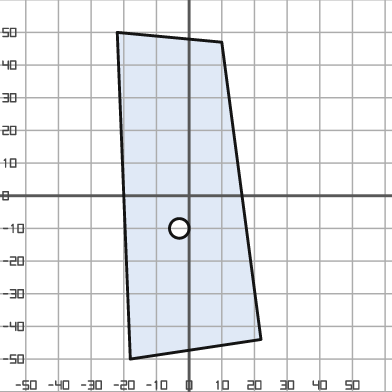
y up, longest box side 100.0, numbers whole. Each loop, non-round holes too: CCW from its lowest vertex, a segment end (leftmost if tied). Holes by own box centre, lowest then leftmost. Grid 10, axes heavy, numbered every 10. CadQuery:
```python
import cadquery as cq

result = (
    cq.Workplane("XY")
    .moveTo(-18.0, -50.0)
    .lineTo(22.0, -44.0)
    .lineTo(10.0, 47.0)
    .lineTo(-22.0, 50.0)
    .close()
    .moveTo(-3.0, -10.0)
    .circle(3.0)
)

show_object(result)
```